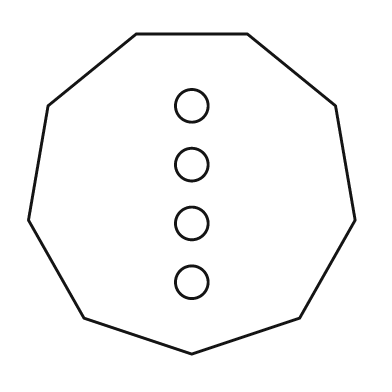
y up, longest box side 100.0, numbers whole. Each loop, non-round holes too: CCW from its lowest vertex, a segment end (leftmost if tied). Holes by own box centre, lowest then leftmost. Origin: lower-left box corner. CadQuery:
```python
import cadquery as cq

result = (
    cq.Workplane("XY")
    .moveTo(50.0, 0.0)
    .lineTo(83.0, 11.0)
    .lineTo(100.0, 41.0)
    .lineTo(94.0, 76.0)
    .lineTo(67.0, 98.0)
    .lineTo(33.0, 98.0)
    .lineTo(6.0, 76.0)
    .lineTo(0.0, 41.0)
    .lineTo(17.0, 11.0)
    .close()
    .moveTo(50.0, 22.0)
    .circle(5.0)
    .moveTo(50.0, 40.0)
    .circle(5.0)
    .moveTo(50.0, 58.0)
    .circle(5.0)
    .moveTo(50.0, 76.0)
    .circle(5.0)
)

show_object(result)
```